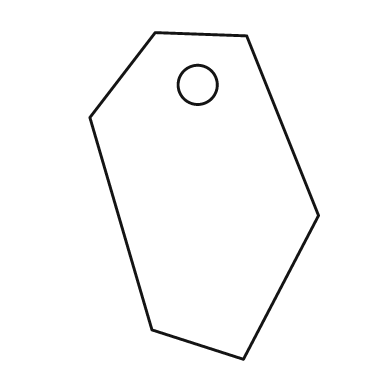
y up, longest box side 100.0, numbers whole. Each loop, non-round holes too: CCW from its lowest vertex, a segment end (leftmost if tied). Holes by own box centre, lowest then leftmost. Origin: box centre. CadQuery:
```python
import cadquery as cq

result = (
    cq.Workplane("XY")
    .moveTo(12.0, -50.0)
    .lineTo(35.0, -6.0)
    .lineTo(13.0, 49.0)
    .lineTo(-15.0, 50.0)
    .lineTo(-35.0, 24.0)
    .lineTo(-16.0, -41.0)
    .close()
    .moveTo(-2.0, 34.0)
    .circle(6.0)
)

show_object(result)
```